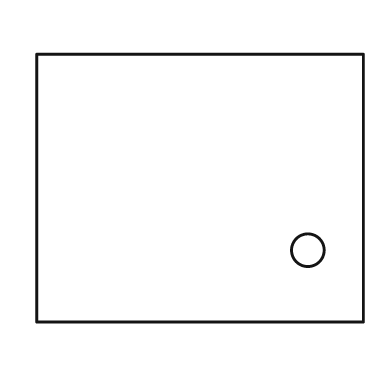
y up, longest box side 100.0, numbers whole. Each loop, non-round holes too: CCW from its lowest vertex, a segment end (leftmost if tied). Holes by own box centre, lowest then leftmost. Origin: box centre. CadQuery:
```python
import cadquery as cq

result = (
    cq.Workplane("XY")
    .moveTo(-50.0, -41.0)
    .lineTo(50.0, -41.0)
    .lineTo(50.0, 41.0)
    .lineTo(-50.0, 41.0)
    .close()
    .moveTo(33.0, -19.0)
    .circle(5.0)
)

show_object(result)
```